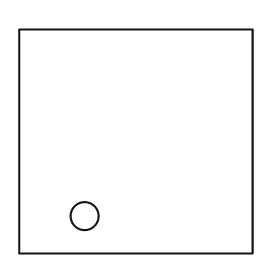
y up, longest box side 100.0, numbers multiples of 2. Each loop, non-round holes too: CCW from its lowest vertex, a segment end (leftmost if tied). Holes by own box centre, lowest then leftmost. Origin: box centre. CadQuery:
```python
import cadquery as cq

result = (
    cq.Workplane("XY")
    .moveTo(-50.0, -48.0)
    .lineTo(50.0, -48.0)
    .lineTo(50.0, 48.0)
    .lineTo(-50.0, 48.0)
    .close()
    .moveTo(-22.0, -32.0)
    .circle(6.0)
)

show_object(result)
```